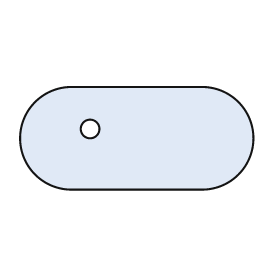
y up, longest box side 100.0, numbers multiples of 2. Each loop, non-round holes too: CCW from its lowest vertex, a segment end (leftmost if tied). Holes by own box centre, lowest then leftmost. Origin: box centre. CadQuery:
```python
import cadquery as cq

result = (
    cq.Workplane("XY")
    .moveTo(-28.0, -22.0)
    .lineTo(28.0, -22.0)
    .threePointArc((50.0, 0.0), (28.0, 22.0))
    .lineTo(-28.0, 22.0)
    .threePointArc((-50.0, 0.0), (-28.0, -22.0))
    .close()
    .moveTo(-20.0, 4.0)
    .circle(4.0)
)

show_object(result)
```